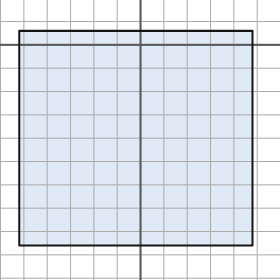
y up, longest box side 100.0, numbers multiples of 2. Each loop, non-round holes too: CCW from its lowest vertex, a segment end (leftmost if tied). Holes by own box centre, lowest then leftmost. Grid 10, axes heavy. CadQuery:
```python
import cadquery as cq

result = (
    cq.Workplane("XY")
    .moveTo(-52.0, -86.0)
    .lineTo(48.0, -86.0)
    .lineTo(48.0, 6.0)
    .lineTo(-52.0, 6.0)
    .close()
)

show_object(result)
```